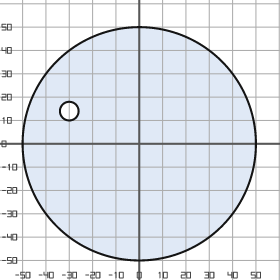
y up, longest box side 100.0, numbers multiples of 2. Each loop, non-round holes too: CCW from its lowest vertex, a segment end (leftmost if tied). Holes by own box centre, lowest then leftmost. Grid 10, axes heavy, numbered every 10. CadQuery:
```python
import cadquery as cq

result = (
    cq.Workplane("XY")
    .moveTo(0.0, 0.0)
    .circle(50.0)
    .moveTo(-30.0, 14.0)
    .circle(4.0)
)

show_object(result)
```